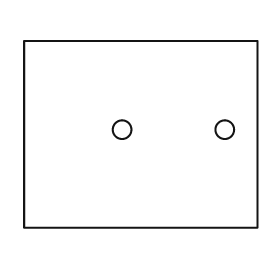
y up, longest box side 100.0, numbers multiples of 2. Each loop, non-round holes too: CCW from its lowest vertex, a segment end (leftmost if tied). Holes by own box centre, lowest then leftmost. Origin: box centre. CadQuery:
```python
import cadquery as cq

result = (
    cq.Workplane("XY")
    .moveTo(-50.0, -40.0)
    .lineTo(50.0, -40.0)
    .lineTo(50.0, 40.0)
    .lineTo(-50.0, 40.0)
    .close()
    .moveTo(-8.0, 2.0)
    .circle(4.0)
    .moveTo(36.0, 2.0)
    .circle(4.0)
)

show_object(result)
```